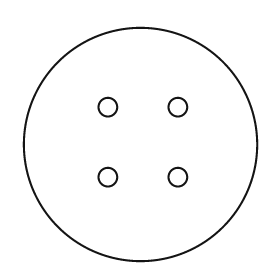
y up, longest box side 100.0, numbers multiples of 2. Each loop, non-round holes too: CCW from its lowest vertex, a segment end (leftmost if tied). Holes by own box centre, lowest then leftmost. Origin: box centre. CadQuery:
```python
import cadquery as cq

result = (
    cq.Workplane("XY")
    .moveTo(0.0, 0.0)
    .circle(50.0)
    .moveTo(-14.0, -14.0)
    .circle(4.0)
    .moveTo(16.0, -14.0)
    .circle(4.0)
    .moveTo(-14.0, 16.0)
    .circle(4.0)
    .moveTo(16.0, 16.0)
    .circle(4.0)
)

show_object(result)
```